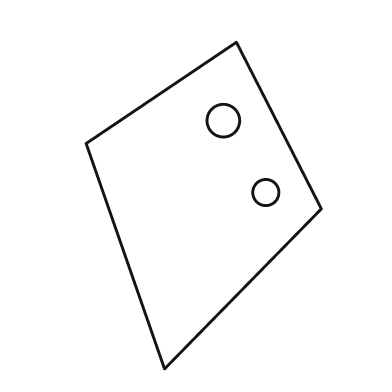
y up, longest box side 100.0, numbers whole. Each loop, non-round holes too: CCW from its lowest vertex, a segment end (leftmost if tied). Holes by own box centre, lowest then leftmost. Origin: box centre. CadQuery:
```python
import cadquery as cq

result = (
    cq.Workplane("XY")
    .moveTo(-12.0, -50.0)
    .lineTo(36.0, -1.0)
    .lineTo(10.0, 50.0)
    .lineTo(-36.0, 19.0)
    .close()
    .moveTo(19.0, 4.0)
    .circle(4.0)
    .moveTo(6.0, 26.0)
    .circle(5.0)
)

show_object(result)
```